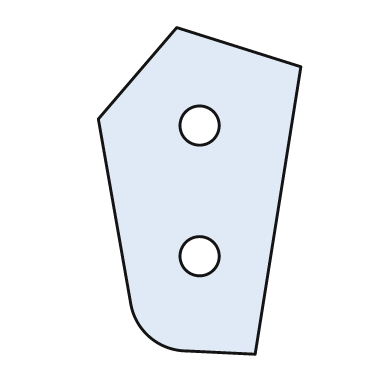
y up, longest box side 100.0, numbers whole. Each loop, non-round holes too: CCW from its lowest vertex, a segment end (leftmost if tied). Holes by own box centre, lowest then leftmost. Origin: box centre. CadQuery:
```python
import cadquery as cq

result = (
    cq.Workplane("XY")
    .moveTo(17.0, -50.0)
    .lineTo(31.0, 38.0)
    .lineTo(-7.0, 50.0)
    .lineTo(-31.0, 22.0)
    .lineTo(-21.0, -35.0)
    .threePointArc((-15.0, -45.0), (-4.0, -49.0))
    .close()
    .moveTo(0.0, -20.0)
    .circle(6.0)
    .moveTo(0.0, 20.0)
    .circle(6.0)
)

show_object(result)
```